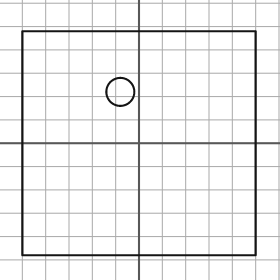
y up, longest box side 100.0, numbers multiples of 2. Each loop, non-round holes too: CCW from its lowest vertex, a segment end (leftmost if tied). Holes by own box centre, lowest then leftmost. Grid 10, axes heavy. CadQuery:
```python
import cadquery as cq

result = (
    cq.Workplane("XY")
    .moveTo(-50.0, -48.0)
    .lineTo(50.0, -48.0)
    .lineTo(50.0, 48.0)
    .lineTo(-50.0, 48.0)
    .close()
    .moveTo(-8.0, 22.0)
    .circle(6.0)
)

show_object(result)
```